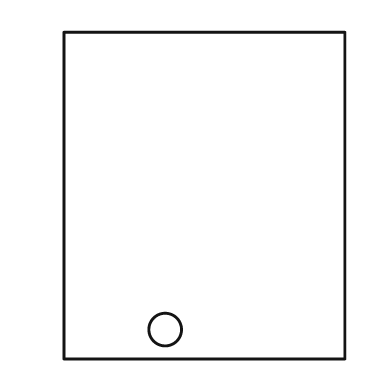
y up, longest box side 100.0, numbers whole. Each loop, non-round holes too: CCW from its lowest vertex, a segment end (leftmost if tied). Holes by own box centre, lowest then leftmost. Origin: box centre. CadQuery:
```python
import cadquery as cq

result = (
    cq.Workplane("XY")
    .moveTo(-43.0, -50.0)
    .lineTo(43.0, -50.0)
    .lineTo(43.0, 50.0)
    .lineTo(-43.0, 50.0)
    .close()
    .moveTo(-12.0, -41.0)
    .circle(5.0)
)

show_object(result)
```